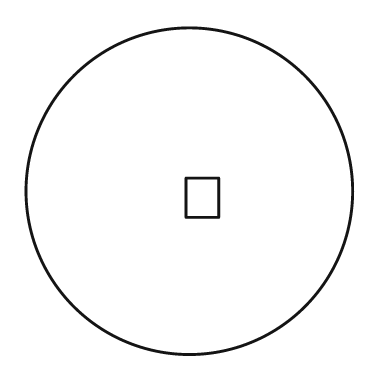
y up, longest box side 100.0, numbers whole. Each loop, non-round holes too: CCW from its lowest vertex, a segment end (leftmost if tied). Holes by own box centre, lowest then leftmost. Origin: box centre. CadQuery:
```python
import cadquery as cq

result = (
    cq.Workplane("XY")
    .moveTo(0.0, 0.0)
    .circle(50.0)
    .moveTo(-1.0, -8.0)
    .lineTo(9.0, -8.0)
    .lineTo(9.0, 4.0)
    .lineTo(-1.0, 4.0)
    .close()
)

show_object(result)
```